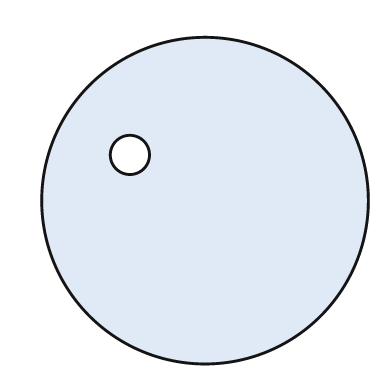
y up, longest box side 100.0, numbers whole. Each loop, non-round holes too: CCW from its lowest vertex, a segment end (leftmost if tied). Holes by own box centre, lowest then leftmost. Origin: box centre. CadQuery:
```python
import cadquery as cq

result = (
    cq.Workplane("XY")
    .moveTo(0.0, 0.0)
    .circle(50.0)
    .moveTo(-23.0, 14.0)
    .circle(6.0)
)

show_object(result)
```